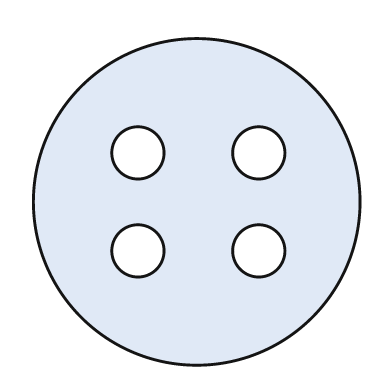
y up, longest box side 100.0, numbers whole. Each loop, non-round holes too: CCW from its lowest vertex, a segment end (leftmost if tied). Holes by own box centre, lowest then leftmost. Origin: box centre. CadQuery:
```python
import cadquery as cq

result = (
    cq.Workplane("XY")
    .moveTo(0.0, 0.0)
    .circle(50.0)
    .moveTo(-18.0, -15.0)
    .circle(8.0)
    .moveTo(19.0, -15.0)
    .circle(8.0)
    .moveTo(-18.0, 15.0)
    .circle(8.0)
    .moveTo(19.0, 15.0)
    .circle(8.0)
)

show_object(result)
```